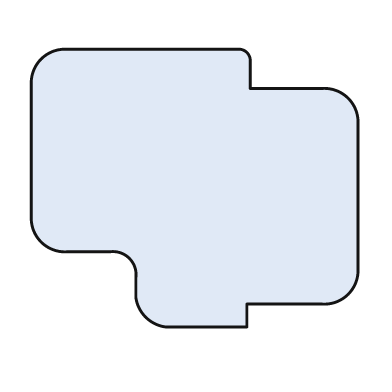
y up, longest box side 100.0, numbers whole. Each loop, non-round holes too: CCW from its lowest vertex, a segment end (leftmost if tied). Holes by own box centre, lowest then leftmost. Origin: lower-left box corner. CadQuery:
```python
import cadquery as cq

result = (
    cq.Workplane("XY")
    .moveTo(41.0, 0.0)
    .lineTo(66.0, 0.0)
    .lineTo(66.0, 7.0)
    .lineTo(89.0, 7.0)
    .threePointArc((97.0, 10.0), (100.0, 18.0))
    .lineTo(100.0, 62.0)
    .threePointArc((97.0, 70.0), (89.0, 73.0))
    .lineTo(67.0, 73.0)
    .lineTo(67.0, 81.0)
    .threePointArc((66.0, 84.0), (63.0, 85.0))
    .lineTo(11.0, 85.0)
    .threePointArc((3.0, 82.0), (0.0, 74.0))
    .lineTo(0.0, 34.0)
    .threePointArc((3.0, 26.0), (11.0, 23.0))
    .lineTo(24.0, 23.0)
    .threePointArc((30.0, 21.0), (32.0, 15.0))
    .lineTo(32.0, 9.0)
    .threePointArc((35.0, 3.0), (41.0, 0.0))
    .close()
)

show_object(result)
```